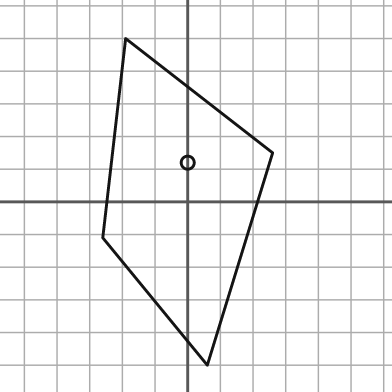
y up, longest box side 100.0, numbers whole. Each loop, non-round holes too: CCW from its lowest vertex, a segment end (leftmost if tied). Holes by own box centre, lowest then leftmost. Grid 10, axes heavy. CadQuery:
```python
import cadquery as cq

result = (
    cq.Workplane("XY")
    .moveTo(6.0, -50.0)
    .lineTo(26.0, 15.0)
    .lineTo(-19.0, 50.0)
    .lineTo(-26.0, -11.0)
    .close()
    .moveTo(0.0, 12.0)
    .circle(2.0)
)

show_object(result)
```